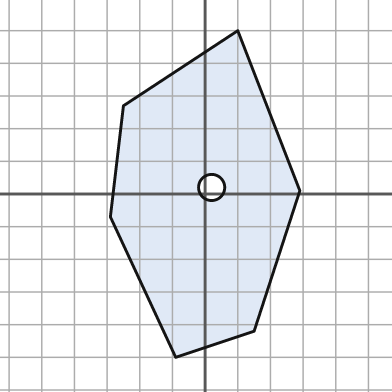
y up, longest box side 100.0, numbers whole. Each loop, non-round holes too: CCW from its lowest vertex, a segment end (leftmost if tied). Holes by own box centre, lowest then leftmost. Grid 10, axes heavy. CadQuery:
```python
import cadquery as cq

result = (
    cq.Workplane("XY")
    .moveTo(-9.0, -50.0)
    .lineTo(15.0, -42.0)
    .lineTo(29.0, 1.0)
    .lineTo(10.0, 50.0)
    .lineTo(-25.0, 27.0)
    .lineTo(-29.0, -7.0)
    .close()
    .moveTo(2.0, 2.0)
    .circle(4.0)
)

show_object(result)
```